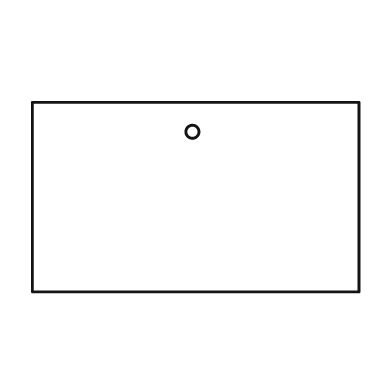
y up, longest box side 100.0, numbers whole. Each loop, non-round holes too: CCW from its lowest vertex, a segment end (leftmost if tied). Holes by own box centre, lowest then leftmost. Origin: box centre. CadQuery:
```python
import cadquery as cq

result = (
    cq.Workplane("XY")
    .moveTo(-50.0, -29.0)
    .lineTo(50.0, -29.0)
    .lineTo(50.0, 29.0)
    .lineTo(-50.0, 29.0)
    .close()
    .moveTo(-1.0, 20.0)
    .circle(2.0)
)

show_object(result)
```